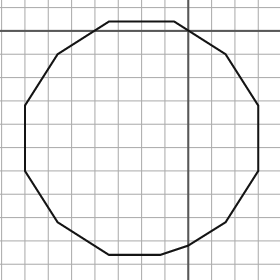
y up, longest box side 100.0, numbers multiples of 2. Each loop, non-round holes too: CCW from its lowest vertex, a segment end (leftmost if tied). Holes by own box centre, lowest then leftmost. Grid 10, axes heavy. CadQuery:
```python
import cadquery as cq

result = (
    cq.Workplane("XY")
    .moveTo(-34.0, -96.0)
    .lineTo(-12.0, -96.0)
    .lineTo(0.0, -92.0)
    .lineTo(16.0, -82.0)
    .lineTo(30.0, -60.0)
    .lineTo(30.0, -32.0)
    .lineTo(16.0, -10.0)
    .lineTo(-6.0, 4.0)
    .lineTo(-34.0, 4.0)
    .lineTo(-56.0, -10.0)
    .lineTo(-70.0, -32.0)
    .lineTo(-70.0, -60.0)
    .lineTo(-56.0, -82.0)
    .close()
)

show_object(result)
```